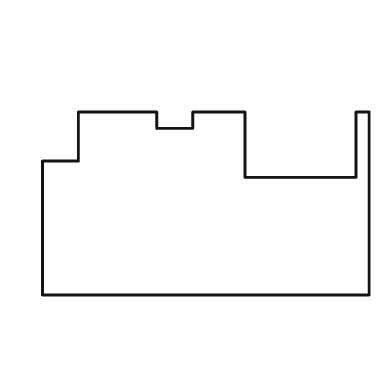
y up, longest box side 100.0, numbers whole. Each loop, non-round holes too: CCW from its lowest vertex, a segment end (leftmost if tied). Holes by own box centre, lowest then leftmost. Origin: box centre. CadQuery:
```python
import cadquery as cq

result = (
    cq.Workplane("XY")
    .moveTo(-50.0, -28.0)
    .lineTo(50.0, -28.0)
    .lineTo(50.0, 28.0)
    .lineTo(46.0, 28.0)
    .lineTo(46.0, 8.0)
    .lineTo(12.0, 8.0)
    .lineTo(12.0, 28.0)
    .lineTo(-4.0, 28.0)
    .lineTo(-4.0, 23.0)
    .lineTo(-15.0, 23.0)
    .lineTo(-15.0, 28.0)
    .lineTo(-39.0, 28.0)
    .lineTo(-39.0, 13.0)
    .lineTo(-50.0, 13.0)
    .close()
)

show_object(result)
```